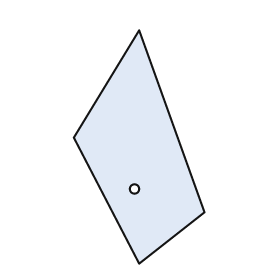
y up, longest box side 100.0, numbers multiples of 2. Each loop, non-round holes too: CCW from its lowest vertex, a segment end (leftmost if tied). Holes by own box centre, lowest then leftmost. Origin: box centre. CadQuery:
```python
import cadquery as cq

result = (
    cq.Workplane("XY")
    .moveTo(0.0, -50.0)
    .lineTo(28.0, -28.0)
    .lineTo(0.0, 50.0)
    .lineTo(-28.0, 4.0)
    .close()
    .moveTo(-2.0, -18.0)
    .circle(2.0)
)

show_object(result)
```